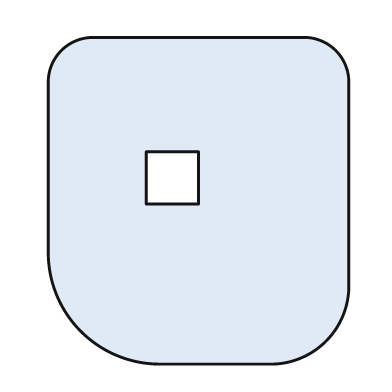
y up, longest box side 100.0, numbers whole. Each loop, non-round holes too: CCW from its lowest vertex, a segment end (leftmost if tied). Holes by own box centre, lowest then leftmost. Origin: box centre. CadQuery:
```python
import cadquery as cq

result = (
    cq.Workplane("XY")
    .moveTo(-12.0, -50.0)
    .lineTo(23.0, -50.0)
    .threePointArc((39.0, -43.0), (46.0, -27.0))
    .lineTo(46.0, 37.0)
    .threePointArc((42.0, 46.0), (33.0, 50.0))
    .lineTo(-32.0, 50.0)
    .threePointArc((-42.0, 46.0), (-46.0, 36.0))
    .lineTo(-46.0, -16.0)
    .threePointArc((-36.0, -40.0), (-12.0, -50.0))
    .close()
    .moveTo(-16.0, -1.0)
    .lineTo(0.0, -1.0)
    .lineTo(0.0, 15.0)
    .lineTo(-16.0, 15.0)
    .close()
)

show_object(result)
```